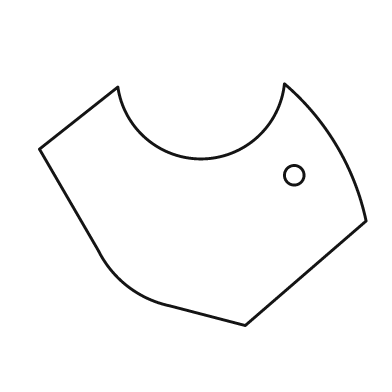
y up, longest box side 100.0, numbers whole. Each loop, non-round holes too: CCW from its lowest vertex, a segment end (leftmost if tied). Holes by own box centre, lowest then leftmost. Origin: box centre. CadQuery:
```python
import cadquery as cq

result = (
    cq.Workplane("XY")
    .moveTo(13.0, -37.0)
    .lineTo(50.0, -5.0)
    .threePointArc((41.0, 18.0), (25.0, 37.0))
    .threePointArc((0.0, 14.0), (-26.0, 36.0))
    .lineTo(-50.0, 17.0)
    .lineTo(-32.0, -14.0)
    .threePointArc((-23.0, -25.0), (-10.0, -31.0))
    .close()
    .moveTo(28.0, 9.0)
    .circle(3.0)
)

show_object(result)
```